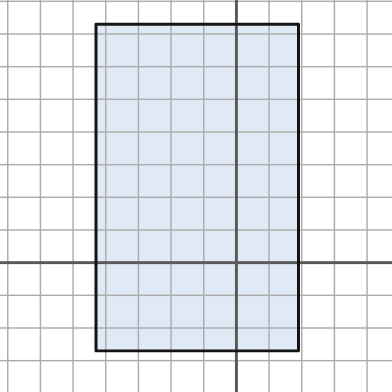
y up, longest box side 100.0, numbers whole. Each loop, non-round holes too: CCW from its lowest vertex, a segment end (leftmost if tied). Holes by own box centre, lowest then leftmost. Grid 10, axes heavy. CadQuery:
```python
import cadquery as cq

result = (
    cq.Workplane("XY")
    .moveTo(-43.0, -27.0)
    .lineTo(19.0, -27.0)
    .lineTo(19.0, 73.0)
    .lineTo(-43.0, 73.0)
    .close()
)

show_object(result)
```